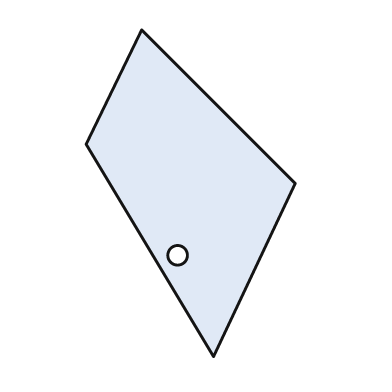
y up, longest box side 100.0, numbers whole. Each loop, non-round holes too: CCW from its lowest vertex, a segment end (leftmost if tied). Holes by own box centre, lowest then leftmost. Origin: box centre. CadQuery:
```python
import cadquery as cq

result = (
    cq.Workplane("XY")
    .moveTo(7.0, -50.0)
    .lineTo(32.0, 3.0)
    .lineTo(-15.0, 50.0)
    .lineTo(-32.0, 15.0)
    .close()
    .moveTo(-4.0, -19.0)
    .circle(3.0)
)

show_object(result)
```